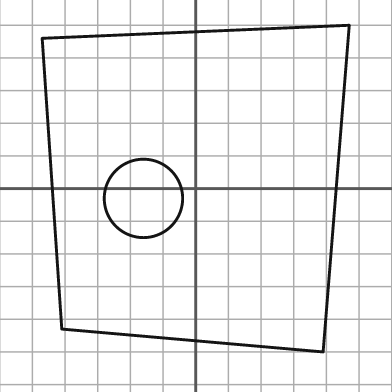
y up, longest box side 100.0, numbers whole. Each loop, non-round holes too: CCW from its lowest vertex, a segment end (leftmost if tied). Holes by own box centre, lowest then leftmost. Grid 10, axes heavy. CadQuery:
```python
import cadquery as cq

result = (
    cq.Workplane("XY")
    .moveTo(39.0, -50.0)
    .lineTo(47.0, 50.0)
    .lineTo(-47.0, 46.0)
    .lineTo(-41.0, -43.0)
    .close()
    .moveTo(-16.0, -3.0)
    .circle(12.0)
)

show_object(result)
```